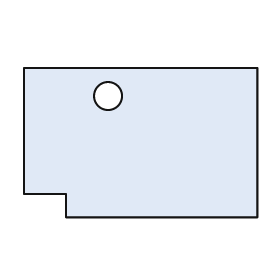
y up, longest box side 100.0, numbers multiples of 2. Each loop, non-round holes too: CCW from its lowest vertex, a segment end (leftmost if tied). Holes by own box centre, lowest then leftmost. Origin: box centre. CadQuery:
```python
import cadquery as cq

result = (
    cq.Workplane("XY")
    .moveTo(-32.0, -32.0)
    .lineTo(50.0, -32.0)
    .lineTo(50.0, 32.0)
    .lineTo(-50.0, 32.0)
    .lineTo(-50.0, -22.0)
    .lineTo(-32.0, -22.0)
    .close()
    .moveTo(-14.0, 20.0)
    .circle(6.0)
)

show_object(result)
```